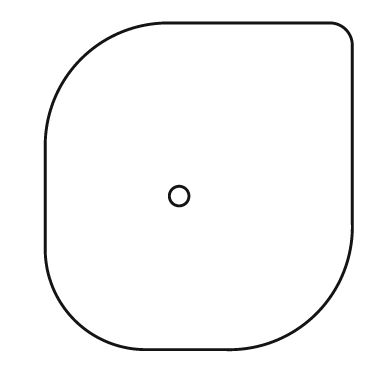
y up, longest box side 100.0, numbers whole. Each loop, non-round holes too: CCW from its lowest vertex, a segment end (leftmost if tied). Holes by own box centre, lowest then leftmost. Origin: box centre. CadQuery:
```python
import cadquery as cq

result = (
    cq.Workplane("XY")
    .moveTo(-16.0, -50.0)
    .lineTo(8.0, -50.0)
    .threePointArc((36.0, -39.0), (47.0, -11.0))
    .lineTo(47.0, 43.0)
    .threePointArc((45.0, 48.0), (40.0, 50.0))
    .lineTo(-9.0, 50.0)
    .threePointArc((-36.0, 39.0), (-47.0, 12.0))
    .lineTo(-47.0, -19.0)
    .threePointArc((-38.0, -41.0), (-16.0, -50.0))
    .close()
    .moveTo(-6.0, -3.0)
    .circle(3.0)
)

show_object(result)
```